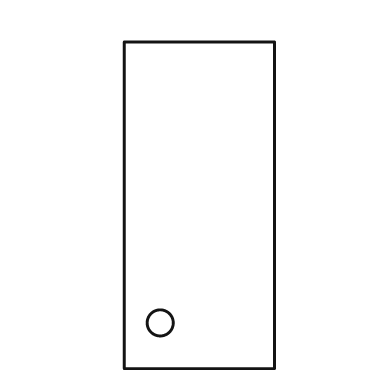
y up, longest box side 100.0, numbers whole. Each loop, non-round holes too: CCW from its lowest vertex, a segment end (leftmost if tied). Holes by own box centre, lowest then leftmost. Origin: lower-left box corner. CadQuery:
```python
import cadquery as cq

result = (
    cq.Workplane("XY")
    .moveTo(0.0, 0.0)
    .lineTo(46.0, 0.0)
    .lineTo(46.0, 100.0)
    .lineTo(0.0, 100.0)
    .close()
    .moveTo(11.0, 14.0)
    .circle(4.0)
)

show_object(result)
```